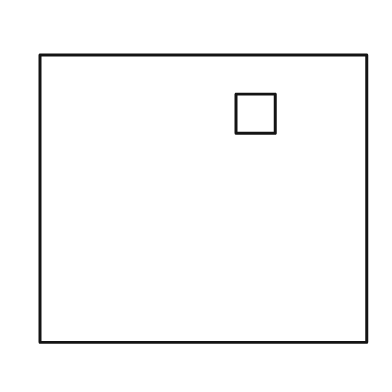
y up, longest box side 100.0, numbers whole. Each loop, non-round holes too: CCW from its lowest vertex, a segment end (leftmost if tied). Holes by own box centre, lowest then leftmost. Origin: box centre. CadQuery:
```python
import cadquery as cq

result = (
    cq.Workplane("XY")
    .moveTo(-50.0, -44.0)
    .lineTo(50.0, -44.0)
    .lineTo(50.0, 44.0)
    .lineTo(-50.0, 44.0)
    .close()
    .moveTo(10.0, 20.0)
    .lineTo(22.0, 20.0)
    .lineTo(22.0, 32.0)
    .lineTo(10.0, 32.0)
    .close()
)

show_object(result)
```